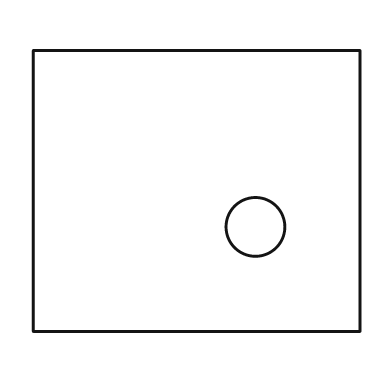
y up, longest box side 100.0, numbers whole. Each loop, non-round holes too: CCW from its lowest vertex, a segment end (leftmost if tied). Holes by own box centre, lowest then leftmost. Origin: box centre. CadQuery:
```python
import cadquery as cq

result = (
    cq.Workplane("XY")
    .moveTo(-50.0, -43.0)
    .lineTo(50.0, -43.0)
    .lineTo(50.0, 43.0)
    .lineTo(-50.0, 43.0)
    .close()
    .moveTo(18.0, -11.0)
    .circle(9.0)
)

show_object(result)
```